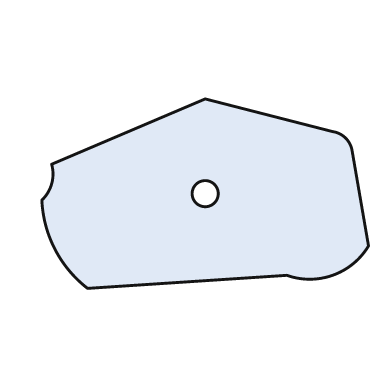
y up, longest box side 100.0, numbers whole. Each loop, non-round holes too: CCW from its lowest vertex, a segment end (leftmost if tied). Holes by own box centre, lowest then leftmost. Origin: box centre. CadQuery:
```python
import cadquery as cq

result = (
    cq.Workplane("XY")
    .moveTo(-36.0, -29.0)
    .lineTo(25.0, -25.0)
    .threePointArc((39.0, -25.0), (50.0, -16.0))
    .lineTo(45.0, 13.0)
    .threePointArc((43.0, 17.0), (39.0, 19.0))
    .lineTo(0.0, 29.0)
    .lineTo(-47.0, 9.0)
    .threePointArc((-47.0, 3.0), (-50.0, -2.0))
    .threePointArc((-46.0, -17.0), (-36.0, -29.0))
    .close()
    .moveTo(0.0, 0.0)
    .circle(4.0)
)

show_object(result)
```